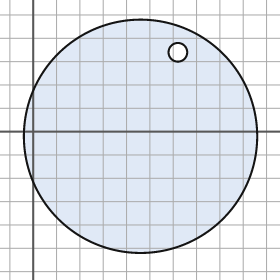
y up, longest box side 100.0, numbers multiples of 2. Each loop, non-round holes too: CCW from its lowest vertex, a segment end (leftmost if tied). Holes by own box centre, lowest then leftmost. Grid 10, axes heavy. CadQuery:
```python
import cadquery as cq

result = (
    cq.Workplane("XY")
    .moveTo(46.0, -2.0)
    .circle(50.0)
    .moveTo(62.0, 34.0)
    .circle(4.0)
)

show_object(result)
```